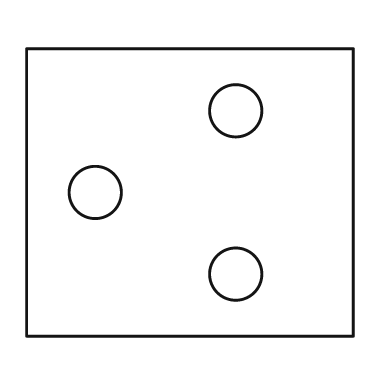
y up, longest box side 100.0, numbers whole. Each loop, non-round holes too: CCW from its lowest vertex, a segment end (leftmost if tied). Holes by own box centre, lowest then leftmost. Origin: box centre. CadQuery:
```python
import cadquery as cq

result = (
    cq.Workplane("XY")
    .moveTo(-50.0, -44.0)
    .lineTo(50.0, -44.0)
    .lineTo(50.0, 44.0)
    .lineTo(-50.0, 44.0)
    .close()
    .moveTo(14.0, -25.0)
    .circle(8.0)
    .moveTo(-29.0, 0.0)
    .circle(8.0)
    .moveTo(14.0, 25.0)
    .circle(8.0)
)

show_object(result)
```